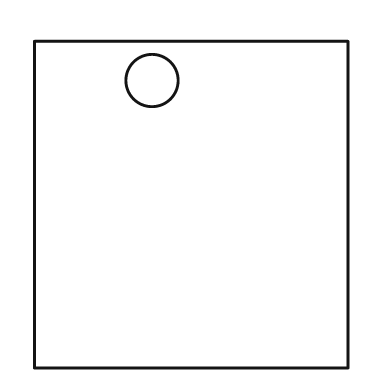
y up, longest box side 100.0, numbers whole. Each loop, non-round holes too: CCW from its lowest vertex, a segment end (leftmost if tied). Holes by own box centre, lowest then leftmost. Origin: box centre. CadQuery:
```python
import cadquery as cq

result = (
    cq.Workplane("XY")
    .moveTo(-48.0, -50.0)
    .lineTo(48.0, -50.0)
    .lineTo(48.0, 50.0)
    .lineTo(-48.0, 50.0)
    .close()
    .moveTo(-12.0, 38.0)
    .circle(8.0)
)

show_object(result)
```